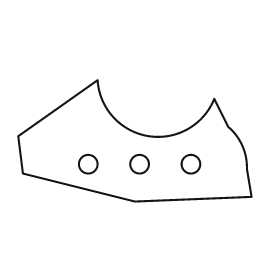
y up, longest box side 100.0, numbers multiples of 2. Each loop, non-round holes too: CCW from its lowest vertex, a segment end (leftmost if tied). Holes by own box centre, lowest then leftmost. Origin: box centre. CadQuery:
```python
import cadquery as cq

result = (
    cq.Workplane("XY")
    .moveTo(0.0, -26.0)
    .lineTo(50.0, -24.0)
    .lineTo(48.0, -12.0)
    .threePointArc((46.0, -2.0), (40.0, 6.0))
    .lineTo(34.0, 18.0)
    .threePointArc((6.0, 2.0), (-16.0, 26.0))
    .lineTo(-50.0, 2.0)
    .lineTo(-48.0, -14.0)
    .close()
    .moveTo(-20.0, -10.0)
    .circle(4.0)
    .moveTo(2.0, -10.0)
    .circle(4.0)
    .moveTo(24.0, -10.0)
    .circle(4.0)
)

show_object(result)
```